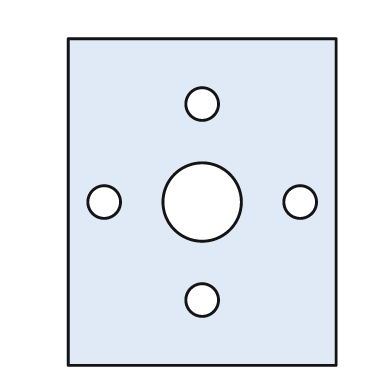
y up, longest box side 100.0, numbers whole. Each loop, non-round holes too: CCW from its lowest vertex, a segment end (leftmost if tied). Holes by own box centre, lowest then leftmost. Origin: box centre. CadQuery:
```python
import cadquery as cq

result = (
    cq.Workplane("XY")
    .moveTo(-41.0, -50.0)
    .lineTo(41.0, -50.0)
    .lineTo(41.0, 50.0)
    .lineTo(-41.0, 50.0)
    .close()
    .moveTo(0.0, -30.0)
    .circle(5.0)
    .moveTo(-30.0, 0.0)
    .circle(5.0)
    .moveTo(0.0, 0.0)
    .circle(12.0)
    .moveTo(30.0, 0.0)
    .circle(5.0)
    .moveTo(0.0, 30.0)
    .circle(5.0)
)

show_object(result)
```